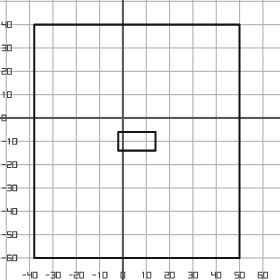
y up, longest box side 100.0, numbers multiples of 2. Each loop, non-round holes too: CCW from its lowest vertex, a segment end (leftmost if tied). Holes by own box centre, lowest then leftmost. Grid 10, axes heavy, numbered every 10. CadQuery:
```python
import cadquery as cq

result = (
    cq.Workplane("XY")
    .moveTo(-38.0, -60.0)
    .lineTo(50.0, -60.0)
    .lineTo(50.0, 40.0)
    .lineTo(-38.0, 40.0)
    .close()
    .moveTo(-2.0, -14.0)
    .lineTo(14.0, -14.0)
    .lineTo(14.0, -6.0)
    .lineTo(-2.0, -6.0)
    .close()
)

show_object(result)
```